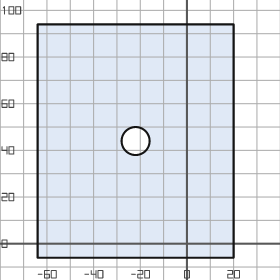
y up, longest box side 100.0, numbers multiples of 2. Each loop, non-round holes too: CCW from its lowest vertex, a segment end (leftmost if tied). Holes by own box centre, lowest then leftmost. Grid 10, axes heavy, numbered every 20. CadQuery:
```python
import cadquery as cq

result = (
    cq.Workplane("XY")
    .moveTo(-64.0, -6.0)
    .lineTo(20.0, -6.0)
    .lineTo(20.0, 94.0)
    .lineTo(-64.0, 94.0)
    .close()
    .moveTo(-22.0, 44.0)
    .circle(6.0)
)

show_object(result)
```